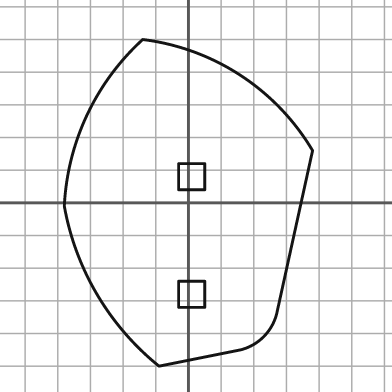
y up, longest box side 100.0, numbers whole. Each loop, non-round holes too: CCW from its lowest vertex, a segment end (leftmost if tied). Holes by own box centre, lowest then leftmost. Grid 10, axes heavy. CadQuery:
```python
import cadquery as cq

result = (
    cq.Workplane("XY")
    .moveTo(-9.0, -50.0)
    .lineTo(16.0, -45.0)
    .threePointArc((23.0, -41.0), (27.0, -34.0))
    .lineTo(38.0, 16.0)
    .threePointArc((16.0, 39.0), (-14.0, 50.0))
    .threePointArc((-31.0, 27.0), (-38.0, -1.0))
    .threePointArc((-28.0, -28.0), (-9.0, -50.0))
    .close()
    .moveTo(-3.0, -32.0)
    .lineTo(5.0, -32.0)
    .lineTo(5.0, -24.0)
    .lineTo(-3.0, -24.0)
    .close()
    .moveTo(-3.0, 4.0)
    .lineTo(5.0, 4.0)
    .lineTo(5.0, 12.0)
    .lineTo(-3.0, 12.0)
    .close()
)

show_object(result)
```